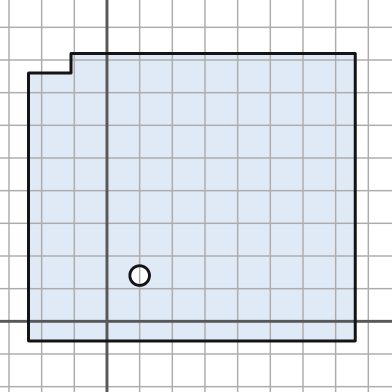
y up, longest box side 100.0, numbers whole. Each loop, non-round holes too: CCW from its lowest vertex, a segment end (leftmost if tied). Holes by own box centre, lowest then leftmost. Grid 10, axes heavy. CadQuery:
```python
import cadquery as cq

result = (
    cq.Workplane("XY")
    .moveTo(-24.0, -6.0)
    .lineTo(76.0, -6.0)
    .lineTo(76.0, 82.0)
    .lineTo(-11.0, 82.0)
    .lineTo(-11.0, 76.0)
    .lineTo(-24.0, 76.0)
    .close()
    .moveTo(10.0, 14.0)
    .circle(3.0)
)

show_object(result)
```